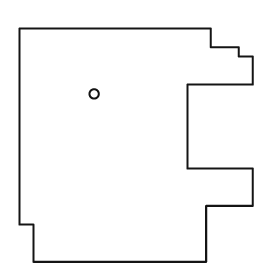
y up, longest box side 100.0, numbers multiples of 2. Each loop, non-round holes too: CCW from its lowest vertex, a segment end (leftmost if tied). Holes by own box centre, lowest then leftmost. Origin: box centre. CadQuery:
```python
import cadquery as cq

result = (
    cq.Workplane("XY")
    .moveTo(-44.0, -50.0)
    .lineTo(30.0, -50.0)
    .lineTo(30.0, -26.0)
    .lineTo(50.0, -26.0)
    .lineTo(50.0, -10.0)
    .lineTo(22.0, -10.0)
    .lineTo(22.0, 26.0)
    .lineTo(50.0, 26.0)
    .lineTo(50.0, 38.0)
    .lineTo(44.0, 38.0)
    .lineTo(44.0, 42.0)
    .lineTo(32.0, 42.0)
    .lineTo(32.0, 50.0)
    .lineTo(-50.0, 50.0)
    .lineTo(-50.0, -34.0)
    .lineTo(-44.0, -34.0)
    .close()
    .moveTo(-18.0, 22.0)
    .circle(2.0)
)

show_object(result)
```